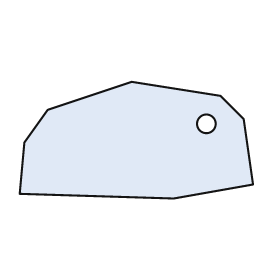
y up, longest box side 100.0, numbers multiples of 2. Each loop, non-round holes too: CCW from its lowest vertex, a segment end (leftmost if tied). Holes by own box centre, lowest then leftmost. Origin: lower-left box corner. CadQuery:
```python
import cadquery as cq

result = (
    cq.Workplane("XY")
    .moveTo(66.0, 0.0)
    .lineTo(100.0, 6.0)
    .lineTo(96.0, 34.0)
    .lineTo(86.0, 44.0)
    .lineTo(48.0, 50.0)
    .lineTo(12.0, 38.0)
    .lineTo(2.0, 24.0)
    .lineTo(0.0, 2.0)
    .close()
    .moveTo(80.0, 32.0)
    .circle(4.0)
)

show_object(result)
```